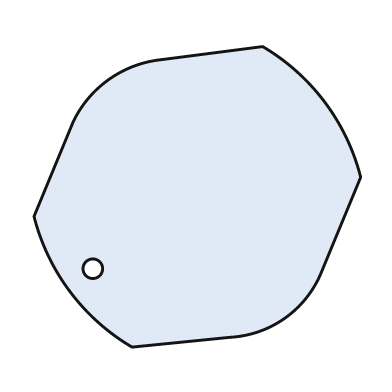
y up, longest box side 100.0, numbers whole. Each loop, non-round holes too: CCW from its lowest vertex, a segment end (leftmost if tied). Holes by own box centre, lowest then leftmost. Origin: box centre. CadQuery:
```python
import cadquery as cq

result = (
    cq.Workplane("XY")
    .moveTo(-20.0, -46.0)
    .lineTo(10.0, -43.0)
    .threePointArc((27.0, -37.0), (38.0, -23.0))
    .lineTo(50.0, 6.0)
    .threePointArc((39.0, 29.0), (20.0, 46.0))
    .lineTo(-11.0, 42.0)
    .threePointArc((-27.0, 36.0), (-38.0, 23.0))
    .lineTo(-50.0, -6.0)
    .threePointArc((-39.0, -29.0), (-20.0, -46.0))
    .close()
    .moveTo(-32.0, -22.0)
    .circle(3.0)
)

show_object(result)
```